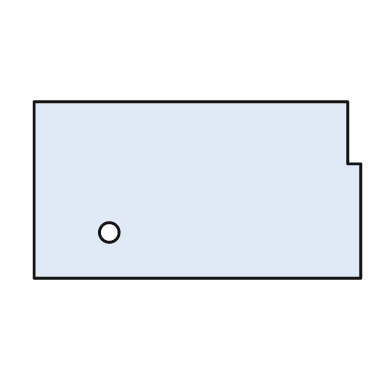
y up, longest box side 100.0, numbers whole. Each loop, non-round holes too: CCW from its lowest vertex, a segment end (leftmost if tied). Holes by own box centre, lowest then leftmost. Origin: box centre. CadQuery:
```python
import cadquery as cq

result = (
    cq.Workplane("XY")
    .moveTo(-50.0, -27.0)
    .lineTo(50.0, -27.0)
    .lineTo(50.0, 8.0)
    .lineTo(46.0, 8.0)
    .lineTo(46.0, 27.0)
    .lineTo(-50.0, 27.0)
    .close()
    .moveTo(-27.0, -13.0)
    .circle(3.0)
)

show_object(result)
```